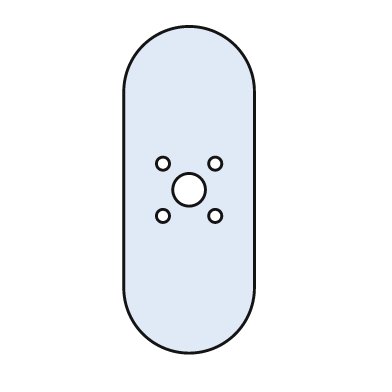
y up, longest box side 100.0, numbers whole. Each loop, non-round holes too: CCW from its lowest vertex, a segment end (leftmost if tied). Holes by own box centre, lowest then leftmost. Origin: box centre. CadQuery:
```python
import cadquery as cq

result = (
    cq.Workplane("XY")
    .moveTo(-20.0, -30.0)
    .threePointArc((0.0, -50.0), (20.0, -30.0))
    .lineTo(20.0, 30.0)
    .threePointArc((0.0, 50.0), (-20.0, 30.0))
    .close()
    .moveTo(-8.0, -8.0)
    .circle(2.0)
    .moveTo(8.0, -8.0)
    .circle(2.0)
    .moveTo(0.0, 0.0)
    .circle(5.0)
    .moveTo(-8.0, 8.0)
    .circle(2.0)
    .moveTo(8.0, 8.0)
    .circle(2.0)
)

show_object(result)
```